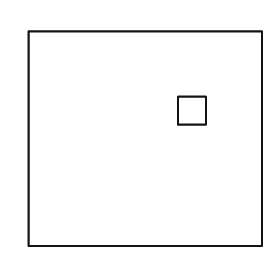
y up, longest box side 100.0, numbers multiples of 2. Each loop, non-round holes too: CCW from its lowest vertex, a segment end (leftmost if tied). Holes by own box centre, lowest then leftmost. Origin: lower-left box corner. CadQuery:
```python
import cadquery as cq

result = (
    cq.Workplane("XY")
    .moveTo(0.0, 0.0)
    .lineTo(100.0, 0.0)
    .lineTo(100.0, 92.0)
    .lineTo(0.0, 92.0)
    .close()
    .moveTo(64.0, 52.0)
    .lineTo(76.0, 52.0)
    .lineTo(76.0, 64.0)
    .lineTo(64.0, 64.0)
    .close()
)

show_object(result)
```